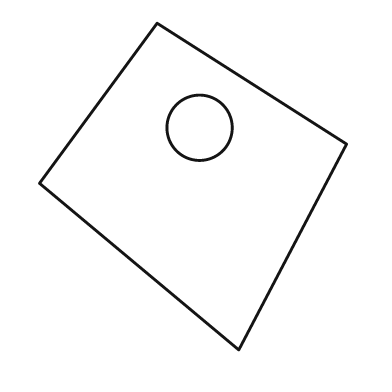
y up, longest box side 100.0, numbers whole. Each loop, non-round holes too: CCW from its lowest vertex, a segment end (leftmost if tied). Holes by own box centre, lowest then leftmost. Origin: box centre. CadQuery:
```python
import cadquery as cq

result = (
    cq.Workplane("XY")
    .moveTo(14.0, -50.0)
    .lineTo(47.0, 13.0)
    .lineTo(-11.0, 50.0)
    .lineTo(-47.0, 1.0)
    .close()
    .moveTo(2.0, 18.0)
    .circle(10.0)
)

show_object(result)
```